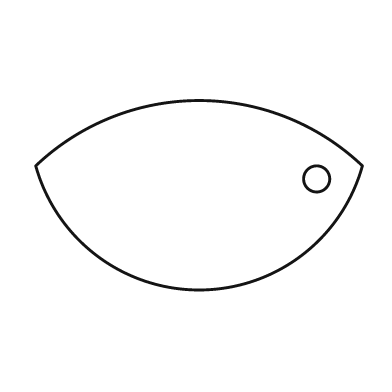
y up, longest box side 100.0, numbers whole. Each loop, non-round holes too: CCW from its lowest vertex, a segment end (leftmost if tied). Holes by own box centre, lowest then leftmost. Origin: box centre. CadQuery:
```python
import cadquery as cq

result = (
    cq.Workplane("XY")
    .moveTo(-50.0, 9.0)
    .threePointArc((0.0, -29.0), (50.0, 9.0))
    .threePointArc((0.0, 29.0), (-50.0, 9.0))
    .close()
    .moveTo(36.0, 5.0)
    .circle(4.0)
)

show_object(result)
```